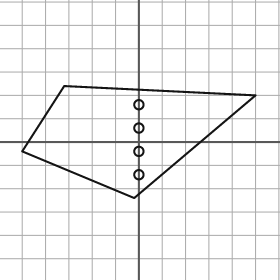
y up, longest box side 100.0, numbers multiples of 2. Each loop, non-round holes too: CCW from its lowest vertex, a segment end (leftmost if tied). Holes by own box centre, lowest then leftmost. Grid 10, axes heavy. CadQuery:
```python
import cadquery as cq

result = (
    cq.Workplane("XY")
    .moveTo(-2.0, -24.0)
    .lineTo(50.0, 20.0)
    .lineTo(-32.0, 24.0)
    .lineTo(-50.0, -4.0)
    .close()
    .moveTo(0.0, -14.0)
    .circle(2.0)
    .moveTo(0.0, -4.0)
    .circle(2.0)
    .moveTo(0.0, 6.0)
    .circle(2.0)
    .moveTo(0.0, 16.0)
    .circle(2.0)
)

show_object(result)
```